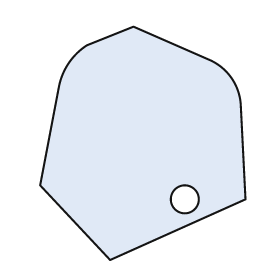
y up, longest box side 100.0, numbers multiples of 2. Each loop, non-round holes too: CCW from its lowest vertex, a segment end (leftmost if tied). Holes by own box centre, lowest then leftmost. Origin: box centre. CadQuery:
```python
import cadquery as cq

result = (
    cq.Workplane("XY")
    .moveTo(-14.0, -50.0)
    .lineTo(44.0, -24.0)
    .lineTo(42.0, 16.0)
    .threePointArc((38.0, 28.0), (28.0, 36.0))
    .lineTo(-4.0, 50.0)
    .lineTo(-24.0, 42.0)
    .threePointArc((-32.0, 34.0), (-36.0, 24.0))
    .lineTo(-44.0, -18.0)
    .close()
    .moveTo(18.0, -24.0)
    .circle(6.0)
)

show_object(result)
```